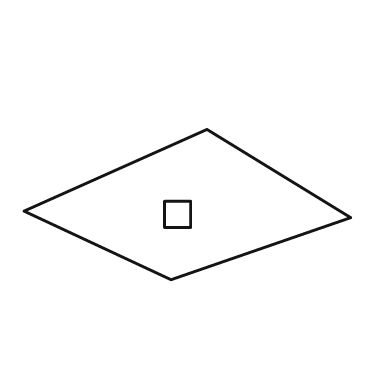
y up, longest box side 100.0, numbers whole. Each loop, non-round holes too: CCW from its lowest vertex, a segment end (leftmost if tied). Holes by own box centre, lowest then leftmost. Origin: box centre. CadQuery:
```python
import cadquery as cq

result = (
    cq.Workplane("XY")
    .moveTo(-5.0, -23.0)
    .lineTo(50.0, -4.0)
    .lineTo(6.0, 23.0)
    .lineTo(-50.0, -2.0)
    .close()
    .moveTo(-7.0, -7.0)
    .lineTo(1.0, -7.0)
    .lineTo(1.0, 1.0)
    .lineTo(-7.0, 1.0)
    .close()
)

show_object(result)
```